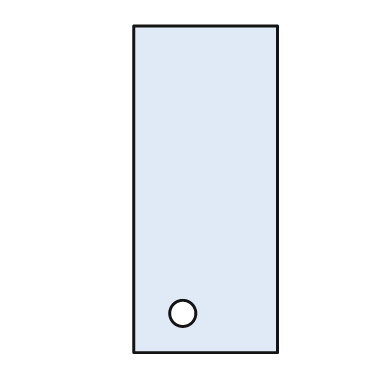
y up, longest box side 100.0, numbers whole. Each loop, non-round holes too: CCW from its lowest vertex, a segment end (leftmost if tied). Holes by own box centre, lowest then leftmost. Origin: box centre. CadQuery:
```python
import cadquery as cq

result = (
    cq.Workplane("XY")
    .moveTo(-22.0, -50.0)
    .lineTo(22.0, -50.0)
    .lineTo(22.0, 50.0)
    .lineTo(-22.0, 50.0)
    .close()
    .moveTo(-7.0, -38.0)
    .circle(4.0)
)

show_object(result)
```